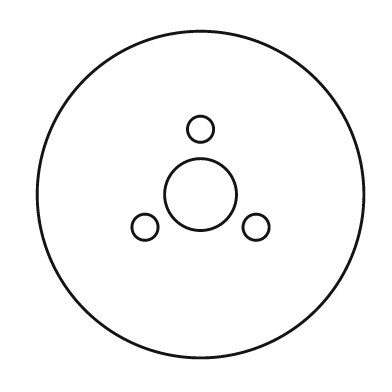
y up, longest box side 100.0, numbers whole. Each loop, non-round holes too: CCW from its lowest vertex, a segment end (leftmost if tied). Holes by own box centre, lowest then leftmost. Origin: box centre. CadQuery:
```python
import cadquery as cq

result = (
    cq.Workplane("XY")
    .moveTo(0.0, 0.0)
    .circle(50.0)
    .moveTo(-17.0, -10.0)
    .circle(4.0)
    .moveTo(17.0, -10.0)
    .circle(4.0)
    .moveTo(0.0, 0.0)
    .circle(11.0)
    .moveTo(0.0, 20.0)
    .circle(4.0)
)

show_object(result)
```